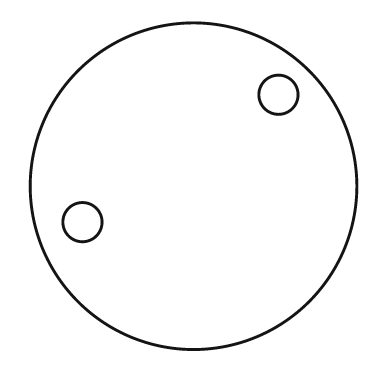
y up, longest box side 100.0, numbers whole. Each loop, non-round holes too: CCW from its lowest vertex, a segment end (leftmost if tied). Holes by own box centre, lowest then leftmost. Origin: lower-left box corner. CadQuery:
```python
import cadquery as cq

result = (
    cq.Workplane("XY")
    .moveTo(50.0, 50.0)
    .circle(50.0)
    .moveTo(16.0, 39.0)
    .circle(6.0)
    .moveTo(76.0, 78.0)
    .circle(6.0)
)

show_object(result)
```